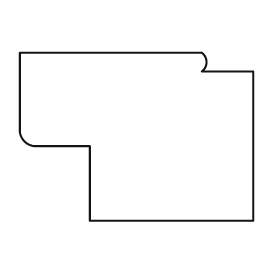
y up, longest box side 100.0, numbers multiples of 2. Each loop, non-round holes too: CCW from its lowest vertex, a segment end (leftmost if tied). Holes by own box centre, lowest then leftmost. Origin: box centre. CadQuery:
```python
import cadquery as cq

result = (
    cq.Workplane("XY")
    .moveTo(-20.0, -36.0)
    .lineTo(50.0, -36.0)
    .lineTo(50.0, 28.0)
    .lineTo(28.0, 28.0)
    .threePointArc((30.0, 32.0), (28.0, 36.0))
    .lineTo(-50.0, 36.0)
    .lineTo(-50.0, 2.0)
    .threePointArc((-48.0, -2.0), (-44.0, -4.0))
    .lineTo(-20.0, -4.0)
    .close()
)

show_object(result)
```